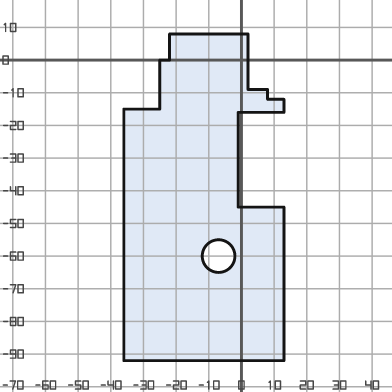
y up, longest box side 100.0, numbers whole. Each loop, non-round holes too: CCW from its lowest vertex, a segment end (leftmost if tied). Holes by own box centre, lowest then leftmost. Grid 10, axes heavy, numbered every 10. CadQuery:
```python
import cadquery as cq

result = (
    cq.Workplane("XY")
    .moveTo(-36.0, -92.0)
    .lineTo(13.0, -92.0)
    .lineTo(13.0, -45.0)
    .lineTo(-1.0, -45.0)
    .lineTo(-1.0, -16.0)
    .lineTo(13.0, -16.0)
    .lineTo(13.0, -12.0)
    .lineTo(8.0, -12.0)
    .lineTo(8.0, -9.0)
    .lineTo(2.0, -9.0)
    .lineTo(2.0, 8.0)
    .lineTo(-22.0, 8.0)
    .lineTo(-22.0, 0.0)
    .lineTo(-25.0, 0.0)
    .lineTo(-25.0, -15.0)
    .lineTo(-36.0, -15.0)
    .close()
    .moveTo(-7.0, -60.0)
    .circle(5.0)
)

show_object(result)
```